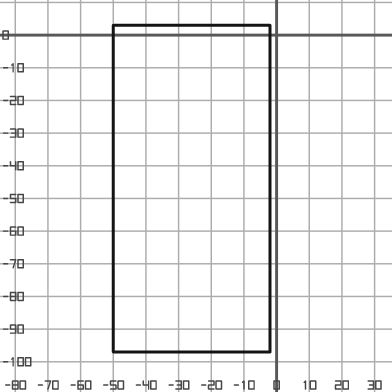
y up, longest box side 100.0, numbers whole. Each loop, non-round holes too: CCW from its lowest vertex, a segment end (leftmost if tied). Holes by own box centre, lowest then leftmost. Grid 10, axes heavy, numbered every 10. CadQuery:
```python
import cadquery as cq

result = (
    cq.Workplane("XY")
    .moveTo(-50.0, -97.0)
    .lineTo(-2.0, -97.0)
    .lineTo(-2.0, 3.0)
    .lineTo(-50.0, 3.0)
    .close()
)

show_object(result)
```